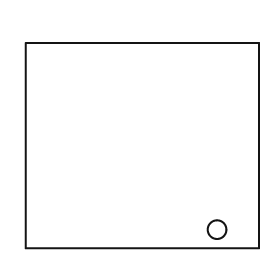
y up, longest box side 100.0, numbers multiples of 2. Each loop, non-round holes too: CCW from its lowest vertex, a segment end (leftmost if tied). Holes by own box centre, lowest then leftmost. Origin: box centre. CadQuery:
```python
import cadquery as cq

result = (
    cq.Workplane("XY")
    .moveTo(-50.0, -44.0)
    .lineTo(50.0, -44.0)
    .lineTo(50.0, 44.0)
    .lineTo(-50.0, 44.0)
    .close()
    .moveTo(32.0, -36.0)
    .circle(4.0)
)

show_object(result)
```